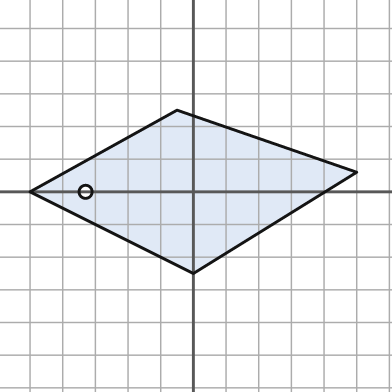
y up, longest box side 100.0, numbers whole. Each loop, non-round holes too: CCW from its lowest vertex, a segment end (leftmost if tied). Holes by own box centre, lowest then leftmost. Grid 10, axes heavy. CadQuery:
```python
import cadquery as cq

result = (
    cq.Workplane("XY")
    .moveTo(0.0, -25.0)
    .lineTo(50.0, 6.0)
    .lineTo(-5.0, 25.0)
    .lineTo(-50.0, 0.0)
    .close()
    .moveTo(-33.0, 0.0)
    .circle(2.0)
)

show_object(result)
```